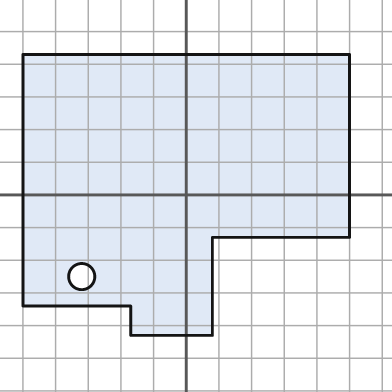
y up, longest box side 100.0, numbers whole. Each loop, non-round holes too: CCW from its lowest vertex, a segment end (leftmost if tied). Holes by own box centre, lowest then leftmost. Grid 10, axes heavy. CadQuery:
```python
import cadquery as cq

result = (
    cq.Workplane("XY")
    .moveTo(-17.0, -43.0)
    .lineTo(8.0, -43.0)
    .lineTo(8.0, -13.0)
    .lineTo(50.0, -13.0)
    .lineTo(50.0, 43.0)
    .lineTo(-50.0, 43.0)
    .lineTo(-50.0, -34.0)
    .lineTo(-17.0, -34.0)
    .close()
    .moveTo(-32.0, -25.0)
    .circle(4.0)
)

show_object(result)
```